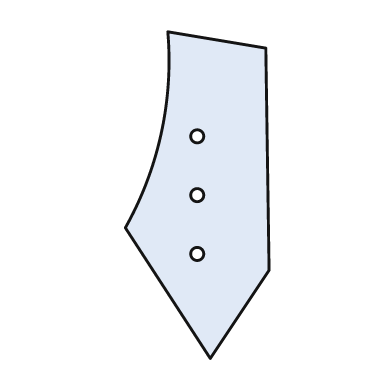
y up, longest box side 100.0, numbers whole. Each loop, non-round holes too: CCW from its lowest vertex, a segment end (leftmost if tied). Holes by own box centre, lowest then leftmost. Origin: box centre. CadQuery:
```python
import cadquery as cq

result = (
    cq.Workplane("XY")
    .moveTo(4.0, -50.0)
    .lineTo(22.0, -23.0)
    .lineTo(21.0, 45.0)
    .lineTo(-9.0, 50.0)
    .threePointArc((-11.0, 19.0), (-22.0, -10.0))
    .close()
    .moveTo(0.0, -18.0)
    .circle(2.0)
    .moveTo(0.0, 0.0)
    .circle(2.0)
    .moveTo(0.0, 18.0)
    .circle(2.0)
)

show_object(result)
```